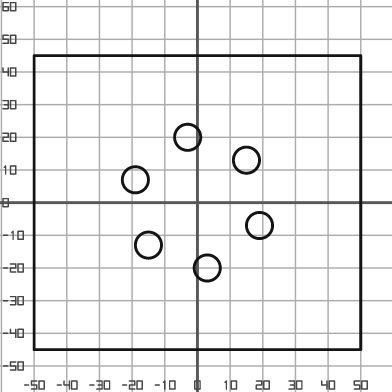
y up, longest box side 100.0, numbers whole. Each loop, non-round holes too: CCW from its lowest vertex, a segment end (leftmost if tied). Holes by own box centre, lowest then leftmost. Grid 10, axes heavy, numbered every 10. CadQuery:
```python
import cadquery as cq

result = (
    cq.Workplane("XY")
    .moveTo(-50.0, -45.0)
    .lineTo(50.0, -45.0)
    .lineTo(50.0, 45.0)
    .lineTo(-50.0, 45.0)
    .close()
    .moveTo(3.0, -20.0)
    .circle(4.0)
    .moveTo(-15.0, -13.0)
    .circle(4.0)
    .moveTo(19.0, -7.0)
    .circle(4.0)
    .moveTo(-19.0, 7.0)
    .circle(4.0)
    .moveTo(15.0, 13.0)
    .circle(4.0)
    .moveTo(-3.0, 20.0)
    .circle(4.0)
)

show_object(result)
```